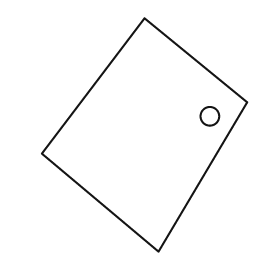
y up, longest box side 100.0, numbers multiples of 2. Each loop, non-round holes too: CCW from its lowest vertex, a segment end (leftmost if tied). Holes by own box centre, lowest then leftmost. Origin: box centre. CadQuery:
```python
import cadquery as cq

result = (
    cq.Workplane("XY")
    .moveTo(6.0, -50.0)
    .lineTo(44.0, 14.0)
    .lineTo(0.0, 50.0)
    .lineTo(-44.0, -8.0)
    .close()
    .moveTo(28.0, 8.0)
    .circle(4.0)
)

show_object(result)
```